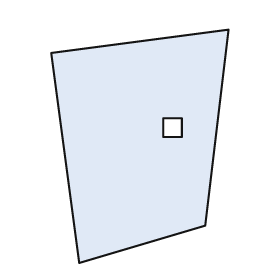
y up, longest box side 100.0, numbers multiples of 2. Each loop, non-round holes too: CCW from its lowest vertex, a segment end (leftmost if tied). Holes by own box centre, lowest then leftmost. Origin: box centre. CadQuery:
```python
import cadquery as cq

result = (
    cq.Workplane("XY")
    .moveTo(-26.0, -50.0)
    .lineTo(28.0, -34.0)
    .lineTo(38.0, 50.0)
    .lineTo(-38.0, 40.0)
    .close()
    .moveTo(10.0, 4.0)
    .lineTo(18.0, 4.0)
    .lineTo(18.0, 12.0)
    .lineTo(10.0, 12.0)
    .close()
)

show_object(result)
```